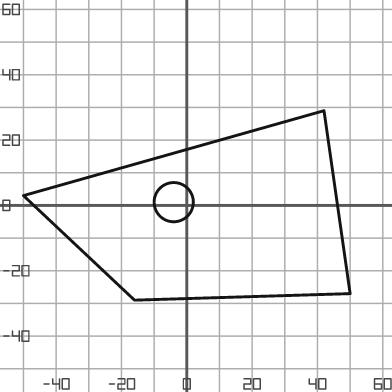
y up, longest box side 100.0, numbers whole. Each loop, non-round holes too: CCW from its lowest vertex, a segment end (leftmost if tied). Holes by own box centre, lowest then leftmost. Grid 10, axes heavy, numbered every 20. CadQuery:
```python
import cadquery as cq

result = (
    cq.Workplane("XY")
    .moveTo(-16.0, -29.0)
    .lineTo(50.0, -27.0)
    .lineTo(42.0, 29.0)
    .lineTo(-50.0, 3.0)
    .close()
    .moveTo(-4.0, 1.0)
    .circle(6.0)
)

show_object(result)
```